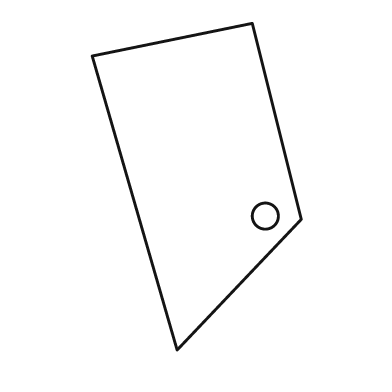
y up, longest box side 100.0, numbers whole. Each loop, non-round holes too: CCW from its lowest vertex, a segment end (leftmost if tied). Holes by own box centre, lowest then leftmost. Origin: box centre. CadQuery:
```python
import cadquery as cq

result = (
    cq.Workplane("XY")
    .moveTo(-6.0, -50.0)
    .lineTo(32.0, -10.0)
    .lineTo(17.0, 50.0)
    .lineTo(-32.0, 40.0)
    .close()
    .moveTo(21.0, -9.0)
    .circle(4.0)
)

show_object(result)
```